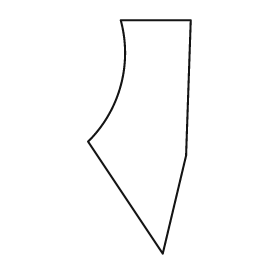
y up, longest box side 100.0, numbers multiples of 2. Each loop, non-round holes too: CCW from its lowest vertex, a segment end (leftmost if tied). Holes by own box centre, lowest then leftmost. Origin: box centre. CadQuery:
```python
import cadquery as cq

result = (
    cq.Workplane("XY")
    .moveTo(10.0, -50.0)
    .lineTo(20.0, -8.0)
    .lineTo(22.0, 50.0)
    .lineTo(-8.0, 50.0)
    .threePointArc((-8.0, 22.0), (-22.0, -2.0))
    .close()
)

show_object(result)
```